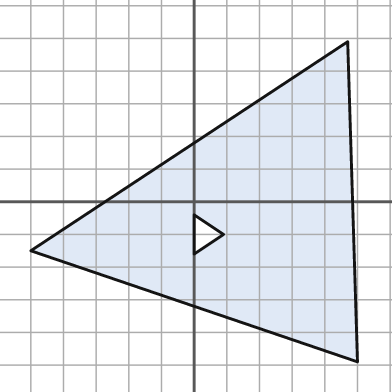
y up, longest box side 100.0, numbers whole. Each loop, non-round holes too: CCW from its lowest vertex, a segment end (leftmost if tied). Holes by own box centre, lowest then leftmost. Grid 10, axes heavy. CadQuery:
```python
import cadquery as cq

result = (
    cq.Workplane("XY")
    .moveTo(50.0, -49.0)
    .lineTo(47.0, 49.0)
    .lineTo(-50.0, -15.0)
    .close()
    .moveTo(0.0, -16.0)
    .lineTo(9.0, -10.0)
    .lineTo(0.0, -4.0)
    .close()
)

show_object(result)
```